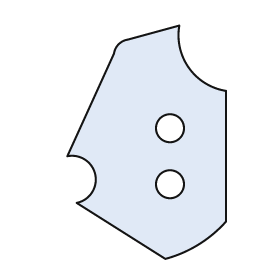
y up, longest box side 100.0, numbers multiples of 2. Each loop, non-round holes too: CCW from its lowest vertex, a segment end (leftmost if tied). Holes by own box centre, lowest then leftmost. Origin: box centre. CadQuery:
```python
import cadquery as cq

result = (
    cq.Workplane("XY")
    .moveTo(8.0, -50.0)
    .threePointArc((22.0, -44.0), (34.0, -34.0))
    .lineTo(34.0, 22.0)
    .threePointArc((18.0, 32.0), (14.0, 50.0))
    .lineTo(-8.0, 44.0)
    .threePointArc((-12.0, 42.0), (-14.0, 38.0))
    .lineTo(-34.0, -6.0)
    .threePointArc((-22.0, -14.0), (-30.0, -26.0))
    .close()
    .moveTo(10.0, -18.0)
    .circle(6.0)
    .moveTo(10.0, 6.0)
    .circle(6.0)
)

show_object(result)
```